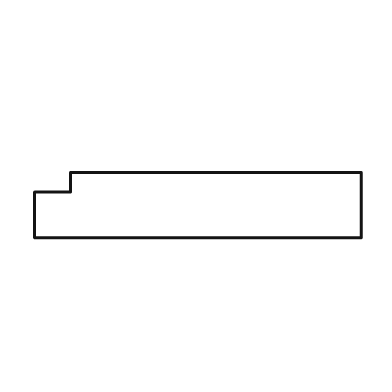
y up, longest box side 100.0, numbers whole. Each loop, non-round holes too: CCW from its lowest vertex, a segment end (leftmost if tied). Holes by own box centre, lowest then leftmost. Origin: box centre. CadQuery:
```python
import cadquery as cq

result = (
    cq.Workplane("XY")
    .moveTo(-50.0, -10.0)
    .lineTo(50.0, -10.0)
    .lineTo(50.0, 10.0)
    .lineTo(-39.0, 10.0)
    .lineTo(-39.0, 4.0)
    .lineTo(-50.0, 4.0)
    .close()
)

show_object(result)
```